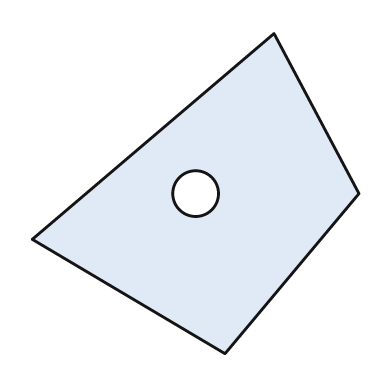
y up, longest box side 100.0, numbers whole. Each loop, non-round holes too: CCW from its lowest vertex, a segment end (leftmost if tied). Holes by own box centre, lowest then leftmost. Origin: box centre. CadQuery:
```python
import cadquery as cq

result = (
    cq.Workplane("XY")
    .moveTo(9.0, -49.0)
    .lineTo(50.0, 0.0)
    .lineTo(24.0, 49.0)
    .lineTo(-50.0, -14.0)
    .close()
    .moveTo(0.0, 0.0)
    .circle(7.0)
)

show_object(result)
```